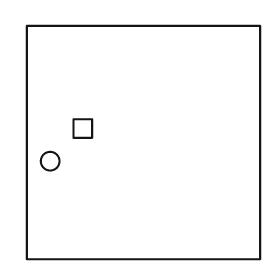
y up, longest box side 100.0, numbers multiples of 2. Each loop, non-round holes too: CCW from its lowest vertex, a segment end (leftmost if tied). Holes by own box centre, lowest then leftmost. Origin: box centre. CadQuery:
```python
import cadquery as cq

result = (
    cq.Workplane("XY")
    .moveTo(-50.0, -50.0)
    .lineTo(50.0, -50.0)
    .lineTo(50.0, 50.0)
    .lineTo(-50.0, 50.0)
    .close()
    .moveTo(-40.0, -8.0)
    .circle(4.0)
    .moveTo(-30.0, 2.0)
    .lineTo(-22.0, 2.0)
    .lineTo(-22.0, 10.0)
    .lineTo(-30.0, 10.0)
    .close()
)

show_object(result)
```